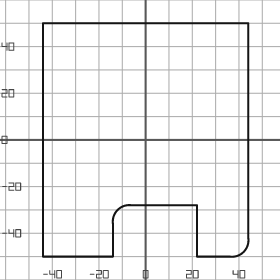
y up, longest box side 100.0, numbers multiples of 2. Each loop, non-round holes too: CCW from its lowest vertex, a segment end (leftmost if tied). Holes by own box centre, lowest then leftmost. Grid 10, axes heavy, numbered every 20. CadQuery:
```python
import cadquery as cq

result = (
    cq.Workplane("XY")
    .moveTo(-44.0, -50.0)
    .lineTo(-14.0, -50.0)
    .lineTo(-14.0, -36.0)
    .threePointArc((-12.0, -30.0), (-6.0, -28.0))
    .lineTo(22.0, -28.0)
    .lineTo(22.0, -50.0)
    .lineTo(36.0, -50.0)
    .threePointArc((42.0, -48.0), (44.0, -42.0))
    .lineTo(44.0, 50.0)
    .lineTo(-44.0, 50.0)
    .close()
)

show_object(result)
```